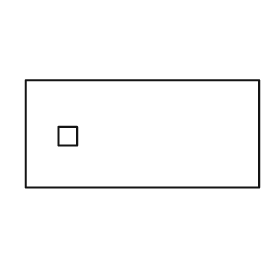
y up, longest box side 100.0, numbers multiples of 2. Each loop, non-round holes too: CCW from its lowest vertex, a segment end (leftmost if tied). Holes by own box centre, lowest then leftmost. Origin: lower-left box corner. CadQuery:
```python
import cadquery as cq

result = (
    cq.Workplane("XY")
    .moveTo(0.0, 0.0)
    .lineTo(100.0, 0.0)
    .lineTo(100.0, 46.0)
    .lineTo(0.0, 46.0)
    .close()
    .moveTo(14.0, 18.0)
    .lineTo(22.0, 18.0)
    .lineTo(22.0, 26.0)
    .lineTo(14.0, 26.0)
    .close()
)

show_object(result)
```